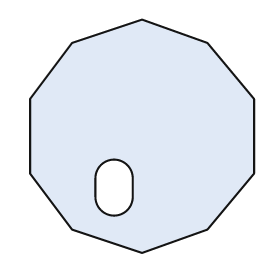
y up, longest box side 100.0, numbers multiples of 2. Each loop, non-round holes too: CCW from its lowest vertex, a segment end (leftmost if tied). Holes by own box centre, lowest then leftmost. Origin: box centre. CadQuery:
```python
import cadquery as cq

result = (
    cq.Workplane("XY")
    .moveTo(0.0, -50.0)
    .lineTo(28.0, -40.0)
    .lineTo(48.0, -16.0)
    .lineTo(48.0, 16.0)
    .lineTo(28.0, 40.0)
    .lineTo(0.0, 50.0)
    .lineTo(-30.0, 40.0)
    .lineTo(-48.0, 16.0)
    .lineTo(-48.0, -16.0)
    .lineTo(-30.0, -40.0)
    .close()
    .moveTo(-20.0, -26.0)
    .threePointArc((-12.0, -34.0), (-4.0, -26.0))
    .lineTo(-4.0, -18.0)
    .threePointArc((-12.0, -10.0), (-20.0, -18.0))
    .close()
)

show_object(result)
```